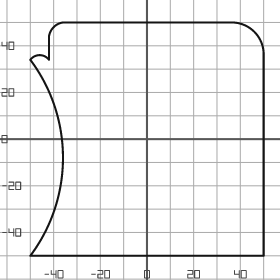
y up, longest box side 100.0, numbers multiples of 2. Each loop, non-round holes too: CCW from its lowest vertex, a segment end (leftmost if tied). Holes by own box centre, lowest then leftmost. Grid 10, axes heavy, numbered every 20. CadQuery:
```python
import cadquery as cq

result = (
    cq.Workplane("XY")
    .moveTo(-50.0, -50.0)
    .lineTo(50.0, -50.0)
    .lineTo(50.0, 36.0)
    .threePointArc((46.0, 46.0), (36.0, 50.0))
    .lineTo(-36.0, 50.0)
    .threePointArc((-40.0, 48.0), (-42.0, 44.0))
    .lineTo(-42.0, 34.0)
    .threePointArc((-46.0, 36.0), (-50.0, 34.0))
    .threePointArc((-36.0, -8.0), (-50.0, -50.0))
    .close()
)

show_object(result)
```